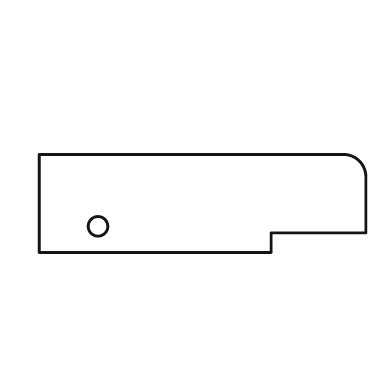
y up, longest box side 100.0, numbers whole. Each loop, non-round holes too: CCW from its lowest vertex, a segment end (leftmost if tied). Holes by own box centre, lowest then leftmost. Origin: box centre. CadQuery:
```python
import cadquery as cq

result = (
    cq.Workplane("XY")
    .moveTo(-50.0, -15.0)
    .lineTo(21.0, -15.0)
    .lineTo(21.0, -9.0)
    .lineTo(50.0, -9.0)
    .lineTo(50.0, 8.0)
    .threePointArc((48.0, 13.0), (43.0, 15.0))
    .lineTo(-50.0, 15.0)
    .close()
    .moveTo(-32.0, -7.0)
    .circle(3.0)
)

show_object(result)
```